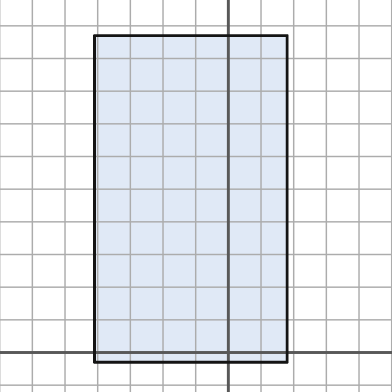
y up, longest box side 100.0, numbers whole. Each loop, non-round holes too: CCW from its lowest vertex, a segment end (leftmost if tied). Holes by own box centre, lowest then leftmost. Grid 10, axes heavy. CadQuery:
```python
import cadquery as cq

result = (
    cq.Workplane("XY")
    .moveTo(-41.0, -3.0)
    .lineTo(18.0, -3.0)
    .lineTo(18.0, 97.0)
    .lineTo(-41.0, 97.0)
    .close()
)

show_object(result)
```